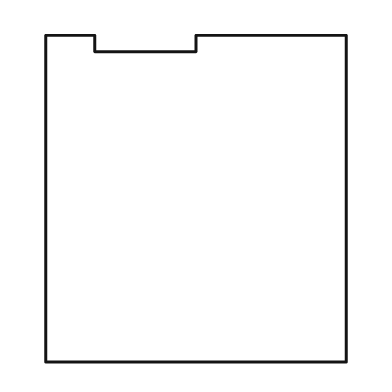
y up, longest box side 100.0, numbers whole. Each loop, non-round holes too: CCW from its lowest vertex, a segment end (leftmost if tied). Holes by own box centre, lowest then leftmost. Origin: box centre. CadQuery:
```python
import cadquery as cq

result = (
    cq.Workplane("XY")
    .moveTo(-46.0, -50.0)
    .lineTo(46.0, -50.0)
    .lineTo(46.0, 50.0)
    .lineTo(0.0, 50.0)
    .lineTo(0.0, 45.0)
    .lineTo(-31.0, 45.0)
    .lineTo(-31.0, 50.0)
    .lineTo(-46.0, 50.0)
    .close()
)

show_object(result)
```